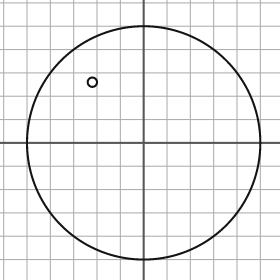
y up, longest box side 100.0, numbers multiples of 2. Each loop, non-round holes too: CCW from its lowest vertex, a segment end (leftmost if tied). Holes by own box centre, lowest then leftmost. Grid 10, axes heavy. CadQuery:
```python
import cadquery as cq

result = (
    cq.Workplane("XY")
    .moveTo(0.0, 0.0)
    .circle(50.0)
    .moveTo(-22.0, 26.0)
    .circle(2.0)
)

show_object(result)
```